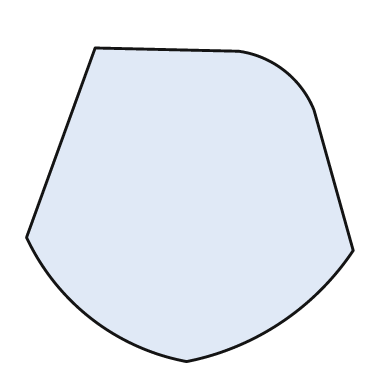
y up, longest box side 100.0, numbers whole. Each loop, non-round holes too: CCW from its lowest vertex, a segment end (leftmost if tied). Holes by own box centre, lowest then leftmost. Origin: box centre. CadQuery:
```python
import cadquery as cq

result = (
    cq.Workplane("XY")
    .moveTo(-1.0, -48.0)
    .threePointArc((28.0, -36.0), (50.0, -14.0))
    .lineTo(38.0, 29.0)
    .threePointArc((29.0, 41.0), (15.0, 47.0))
    .lineTo(-29.0, 48.0)
    .lineTo(-50.0, -10.0)
    .threePointArc((-30.0, -35.0), (-1.0, -48.0))
    .close()
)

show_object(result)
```